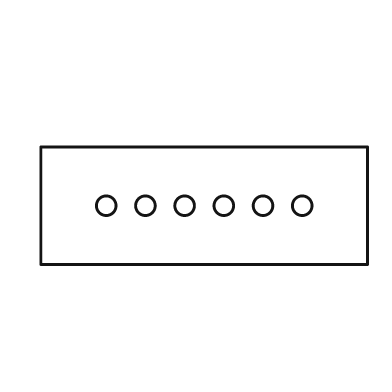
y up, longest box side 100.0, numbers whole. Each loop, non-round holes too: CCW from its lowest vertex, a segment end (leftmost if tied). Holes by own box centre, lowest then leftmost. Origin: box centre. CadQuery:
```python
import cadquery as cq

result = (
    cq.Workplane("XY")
    .moveTo(-50.0, -18.0)
    .lineTo(50.0, -18.0)
    .lineTo(50.0, 18.0)
    .lineTo(-50.0, 18.0)
    .close()
    .moveTo(-30.0, 0.0)
    .circle(3.0)
    .moveTo(-18.0, 0.0)
    .circle(3.0)
    .moveTo(-6.0, 0.0)
    .circle(3.0)
    .moveTo(6.0, 0.0)
    .circle(3.0)
    .moveTo(18.0, 0.0)
    .circle(3.0)
    .moveTo(30.0, 0.0)
    .circle(3.0)
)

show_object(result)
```